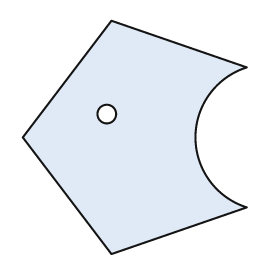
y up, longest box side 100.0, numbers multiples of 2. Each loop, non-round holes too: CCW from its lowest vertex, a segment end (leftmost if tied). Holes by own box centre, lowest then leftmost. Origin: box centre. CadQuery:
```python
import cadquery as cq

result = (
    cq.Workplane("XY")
    .moveTo(-10.0, -50.0)
    .lineTo(48.0, -30.0)
    .threePointArc((26.0, 0.0), (48.0, 30.0))
    .lineTo(-10.0, 50.0)
    .lineTo(-48.0, 0.0)
    .close()
    .moveTo(-12.0, 10.0)
    .circle(4.0)
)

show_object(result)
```